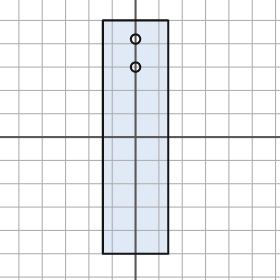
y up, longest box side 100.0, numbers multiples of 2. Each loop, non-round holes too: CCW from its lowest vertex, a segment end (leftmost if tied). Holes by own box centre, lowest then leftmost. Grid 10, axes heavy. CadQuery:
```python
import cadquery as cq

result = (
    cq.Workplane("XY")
    .moveTo(-14.0, -50.0)
    .lineTo(14.0, -50.0)
    .lineTo(14.0, 50.0)
    .lineTo(-14.0, 50.0)
    .close()
    .moveTo(0.0, 30.0)
    .circle(2.0)
    .moveTo(0.0, 42.0)
    .circle(2.0)
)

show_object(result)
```